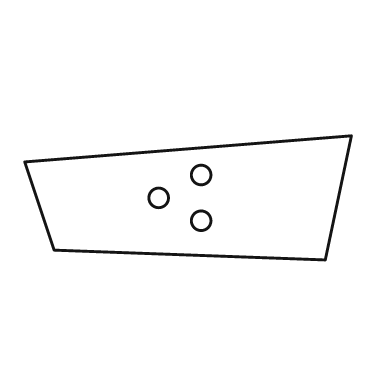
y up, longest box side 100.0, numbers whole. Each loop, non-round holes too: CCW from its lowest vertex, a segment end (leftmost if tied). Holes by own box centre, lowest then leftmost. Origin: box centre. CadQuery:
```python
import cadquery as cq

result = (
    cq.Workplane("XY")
    .moveTo(42.0, -19.0)
    .lineTo(50.0, 19.0)
    .lineTo(-50.0, 11.0)
    .lineTo(-41.0, -16.0)
    .close()
    .moveTo(4.0, -7.0)
    .circle(3.0)
    .moveTo(-9.0, 0.0)
    .circle(3.0)
    .moveTo(4.0, 7.0)
    .circle(3.0)
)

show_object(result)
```